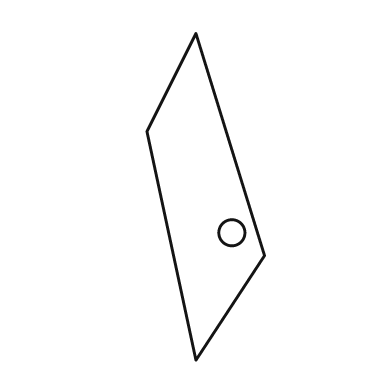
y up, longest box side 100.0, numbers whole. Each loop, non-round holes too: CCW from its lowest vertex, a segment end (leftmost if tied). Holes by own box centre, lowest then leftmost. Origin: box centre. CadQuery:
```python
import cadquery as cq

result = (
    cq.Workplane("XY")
    .moveTo(-3.0, -50.0)
    .lineTo(18.0, -18.0)
    .lineTo(-3.0, 50.0)
    .lineTo(-18.0, 20.0)
    .close()
    .moveTo(8.0, -11.0)
    .circle(4.0)
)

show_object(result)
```